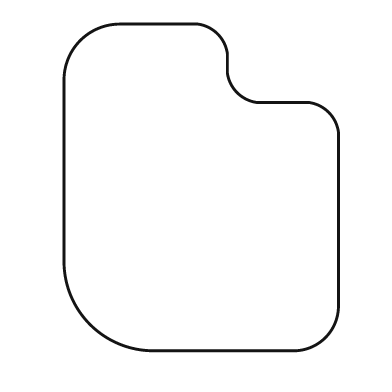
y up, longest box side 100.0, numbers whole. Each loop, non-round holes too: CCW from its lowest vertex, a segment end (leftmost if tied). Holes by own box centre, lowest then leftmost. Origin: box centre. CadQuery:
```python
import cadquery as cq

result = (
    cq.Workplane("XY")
    .moveTo(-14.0, -50.0)
    .lineTo(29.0, -50.0)
    .threePointArc((38.0, -46.0), (42.0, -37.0))
    .lineTo(42.0, 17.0)
    .threePointArc((39.0, 23.0), (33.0, 26.0))
    .lineTo(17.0, 26.0)
    .threePointArc((11.0, 29.0), (8.0, 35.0))
    .lineTo(8.0, 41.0)
    .threePointArc((5.0, 47.0), (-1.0, 50.0))
    .lineTo(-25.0, 50.0)
    .threePointArc((-37.0, 45.0), (-42.0, 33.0))
    .lineTo(-42.0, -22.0)
    .threePointArc((-34.0, -42.0), (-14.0, -50.0))
    .close()
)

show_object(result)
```